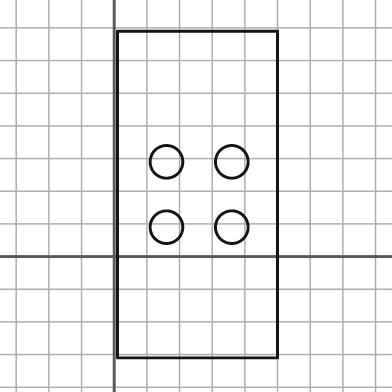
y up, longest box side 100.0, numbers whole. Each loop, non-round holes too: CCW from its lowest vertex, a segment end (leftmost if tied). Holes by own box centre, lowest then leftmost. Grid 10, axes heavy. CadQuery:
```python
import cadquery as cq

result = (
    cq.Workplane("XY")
    .moveTo(1.0, -31.0)
    .lineTo(50.0, -31.0)
    .lineTo(50.0, 69.0)
    .lineTo(1.0, 69.0)
    .close()
    .moveTo(16.0, 9.0)
    .circle(5.0)
    .moveTo(36.0, 9.0)
    .circle(5.0)
    .moveTo(16.0, 29.0)
    .circle(5.0)
    .moveTo(36.0, 29.0)
    .circle(5.0)
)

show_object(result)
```